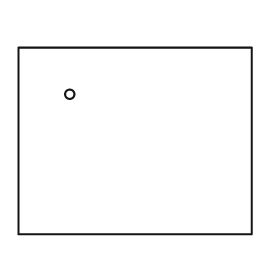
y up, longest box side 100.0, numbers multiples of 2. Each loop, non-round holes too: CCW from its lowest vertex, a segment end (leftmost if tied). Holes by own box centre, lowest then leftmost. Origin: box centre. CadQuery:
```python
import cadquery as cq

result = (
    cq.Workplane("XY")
    .moveTo(-50.0, -40.0)
    .lineTo(50.0, -40.0)
    .lineTo(50.0, 40.0)
    .lineTo(-50.0, 40.0)
    .close()
    .moveTo(-28.0, 20.0)
    .circle(2.0)
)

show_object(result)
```